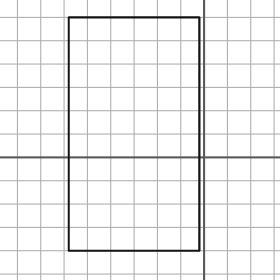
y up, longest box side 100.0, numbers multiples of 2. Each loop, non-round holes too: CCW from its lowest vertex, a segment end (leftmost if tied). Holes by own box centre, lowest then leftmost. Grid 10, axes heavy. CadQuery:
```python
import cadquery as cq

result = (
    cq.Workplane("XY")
    .moveTo(-58.0, -40.0)
    .lineTo(-2.0, -40.0)
    .lineTo(-2.0, 60.0)
    .lineTo(-58.0, 60.0)
    .close()
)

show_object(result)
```